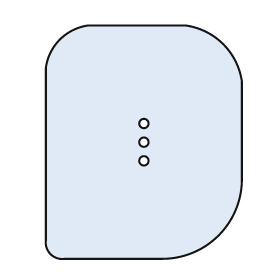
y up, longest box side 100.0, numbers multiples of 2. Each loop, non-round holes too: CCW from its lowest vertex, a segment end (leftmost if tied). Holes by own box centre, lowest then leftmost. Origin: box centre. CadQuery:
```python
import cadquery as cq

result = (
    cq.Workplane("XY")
    .moveTo(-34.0, -50.0)
    .lineTo(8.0, -50.0)
    .threePointArc((32.0, -40.0), (42.0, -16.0))
    .lineTo(42.0, 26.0)
    .threePointArc((34.0, 42.0), (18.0, 50.0))
    .lineTo(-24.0, 50.0)
    .threePointArc((-36.0, 44.0), (-42.0, 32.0))
    .lineTo(-42.0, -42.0)
    .threePointArc((-40.0, -48.0), (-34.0, -50.0))
    .close()
    .moveTo(0.0, -8.0)
    .circle(2.0)
    .moveTo(0.0, 0.0)
    .circle(2.0)
    .moveTo(0.0, 8.0)
    .circle(2.0)
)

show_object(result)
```